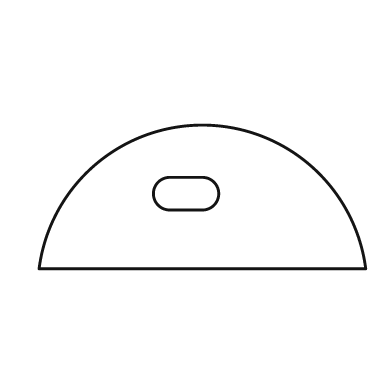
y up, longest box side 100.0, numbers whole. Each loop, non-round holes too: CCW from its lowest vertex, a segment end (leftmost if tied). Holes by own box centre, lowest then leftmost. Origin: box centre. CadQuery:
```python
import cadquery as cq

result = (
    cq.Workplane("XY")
    .moveTo(-50.0, -22.0)
    .lineTo(50.0, -22.0)
    .threePointArc((0.0, 22.0), (-50.0, -22.0))
    .close()
    .moveTo(-10.0, -4.0)
    .lineTo(0.0, -4.0)
    .threePointArc((5.0, 1.0), (0.0, 6.0))
    .lineTo(-10.0, 6.0)
    .threePointArc((-15.0, 1.0), (-10.0, -4.0))
    .close()
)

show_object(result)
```